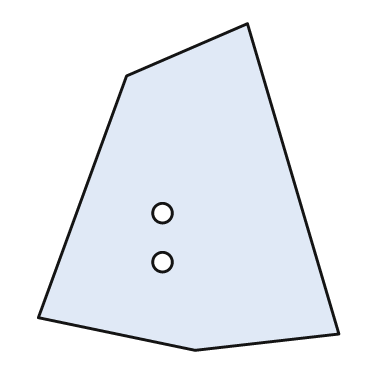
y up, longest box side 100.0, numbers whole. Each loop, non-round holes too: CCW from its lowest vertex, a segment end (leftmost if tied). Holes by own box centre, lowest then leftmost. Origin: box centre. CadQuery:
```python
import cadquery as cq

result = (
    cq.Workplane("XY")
    .moveTo(2.0, -50.0)
    .lineTo(46.0, -45.0)
    .lineTo(18.0, 50.0)
    .lineTo(-19.0, 34.0)
    .lineTo(-46.0, -40.0)
    .close()
    .moveTo(-8.0, -23.0)
    .circle(3.0)
    .moveTo(-8.0, -8.0)
    .circle(3.0)
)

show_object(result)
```